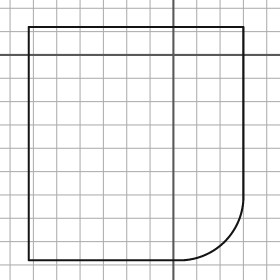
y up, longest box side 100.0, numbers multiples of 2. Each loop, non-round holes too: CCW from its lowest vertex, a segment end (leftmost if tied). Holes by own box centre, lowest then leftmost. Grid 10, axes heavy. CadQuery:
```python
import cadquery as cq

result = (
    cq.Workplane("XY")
    .moveTo(-62.0, -88.0)
    .lineTo(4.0, -88.0)
    .threePointArc((22.0, -80.0), (30.0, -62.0))
    .lineTo(30.0, 12.0)
    .lineTo(-62.0, 12.0)
    .close()
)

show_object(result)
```